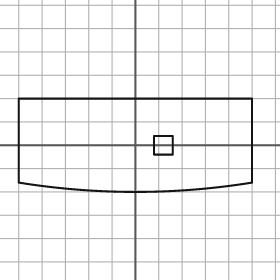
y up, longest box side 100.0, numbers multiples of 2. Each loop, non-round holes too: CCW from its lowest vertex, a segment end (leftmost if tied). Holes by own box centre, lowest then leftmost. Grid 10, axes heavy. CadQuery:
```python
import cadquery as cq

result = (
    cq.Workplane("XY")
    .moveTo(-50.0, -16.0)
    .threePointArc((0.0, -20.0), (50.0, -16.0))
    .lineTo(50.0, 20.0)
    .lineTo(-50.0, 20.0)
    .close()
    .moveTo(8.0, -4.0)
    .lineTo(16.0, -4.0)
    .lineTo(16.0, 4.0)
    .lineTo(8.0, 4.0)
    .close()
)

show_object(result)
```